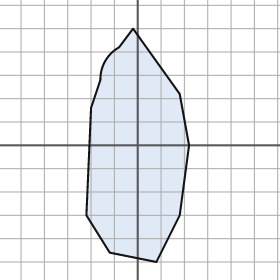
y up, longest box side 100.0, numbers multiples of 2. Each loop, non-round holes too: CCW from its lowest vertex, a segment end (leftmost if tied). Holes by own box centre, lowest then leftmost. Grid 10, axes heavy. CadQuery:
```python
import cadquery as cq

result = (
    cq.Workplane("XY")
    .moveTo(8.0, -50.0)
    .lineTo(18.0, -30.0)
    .lineTo(22.0, 0.0)
    .lineTo(18.0, 22.0)
    .lineTo(-2.0, 50.0)
    .lineTo(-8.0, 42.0)
    .threePointArc((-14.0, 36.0), (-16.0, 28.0))
    .lineTo(-20.0, 16.0)
    .lineTo(-22.0, -30.0)
    .lineTo(-12.0, -46.0)
    .close()
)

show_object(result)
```